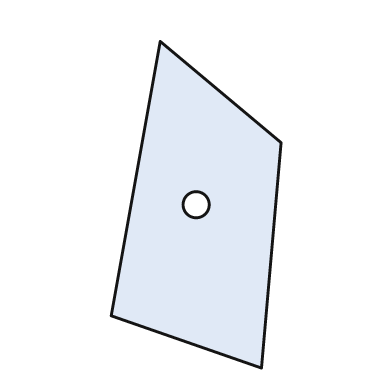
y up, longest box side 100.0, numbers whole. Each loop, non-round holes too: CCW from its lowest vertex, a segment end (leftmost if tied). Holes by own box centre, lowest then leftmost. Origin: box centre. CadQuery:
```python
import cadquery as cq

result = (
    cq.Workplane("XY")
    .moveTo(20.0, -50.0)
    .lineTo(26.0, 19.0)
    .lineTo(-11.0, 50.0)
    .lineTo(-26.0, -34.0)
    .close()
    .moveTo(0.0, 0.0)
    .circle(4.0)
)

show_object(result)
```